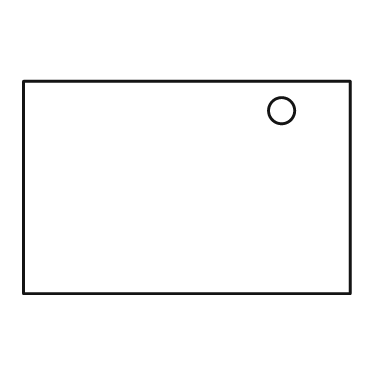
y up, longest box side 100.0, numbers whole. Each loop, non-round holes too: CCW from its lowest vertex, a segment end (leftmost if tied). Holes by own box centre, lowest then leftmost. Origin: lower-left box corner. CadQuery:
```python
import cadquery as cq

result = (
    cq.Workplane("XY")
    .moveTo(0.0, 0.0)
    .lineTo(100.0, 0.0)
    .lineTo(100.0, 65.0)
    .lineTo(0.0, 65.0)
    .close()
    .moveTo(79.0, 56.0)
    .circle(4.0)
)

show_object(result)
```